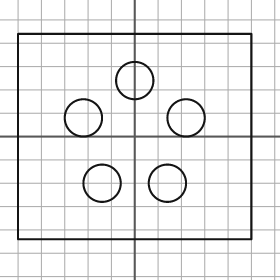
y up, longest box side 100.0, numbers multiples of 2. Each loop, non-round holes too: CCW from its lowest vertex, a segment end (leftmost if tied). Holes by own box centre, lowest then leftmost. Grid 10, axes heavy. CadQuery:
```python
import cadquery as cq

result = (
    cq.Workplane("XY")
    .moveTo(-50.0, -44.0)
    .lineTo(50.0, -44.0)
    .lineTo(50.0, 44.0)
    .lineTo(-50.0, 44.0)
    .close()
    .moveTo(-14.0, -20.0)
    .circle(8.0)
    .moveTo(14.0, -20.0)
    .circle(8.0)
    .moveTo(-22.0, 8.0)
    .circle(8.0)
    .moveTo(22.0, 8.0)
    .circle(8.0)
    .moveTo(0.0, 24.0)
    .circle(8.0)
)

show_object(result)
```